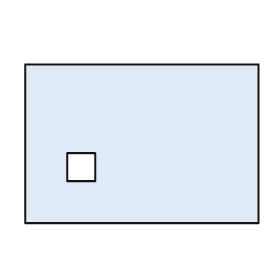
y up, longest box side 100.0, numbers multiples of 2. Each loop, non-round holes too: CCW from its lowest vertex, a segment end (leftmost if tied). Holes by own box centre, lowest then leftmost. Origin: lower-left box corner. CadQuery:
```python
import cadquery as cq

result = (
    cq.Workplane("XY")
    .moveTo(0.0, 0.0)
    .lineTo(100.0, 0.0)
    .lineTo(100.0, 68.0)
    .lineTo(0.0, 68.0)
    .close()
    .moveTo(18.0, 18.0)
    .lineTo(30.0, 18.0)
    .lineTo(30.0, 30.0)
    .lineTo(18.0, 30.0)
    .close()
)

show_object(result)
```